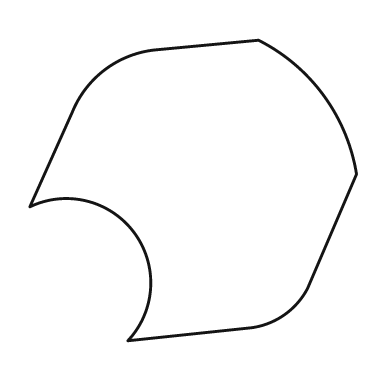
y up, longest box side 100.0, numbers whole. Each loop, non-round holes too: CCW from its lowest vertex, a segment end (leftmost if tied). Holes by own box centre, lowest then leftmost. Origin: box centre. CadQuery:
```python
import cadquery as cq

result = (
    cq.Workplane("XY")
    .moveTo(-20.0, -46.0)
    .lineTo(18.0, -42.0)
    .threePointArc((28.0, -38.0), (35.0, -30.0))
    .lineTo(50.0, 5.0)
    .threePointArc((40.0, 29.0), (20.0, 46.0))
    .lineTo(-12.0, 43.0)
    .threePointArc((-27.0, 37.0), (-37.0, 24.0))
    .lineTo(-50.0, -5.0)
    .threePointArc((-18.0, -13.0), (-20.0, -46.0))
    .close()
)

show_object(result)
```